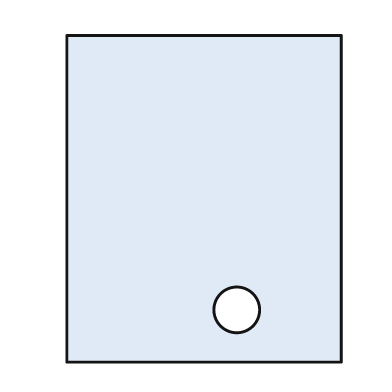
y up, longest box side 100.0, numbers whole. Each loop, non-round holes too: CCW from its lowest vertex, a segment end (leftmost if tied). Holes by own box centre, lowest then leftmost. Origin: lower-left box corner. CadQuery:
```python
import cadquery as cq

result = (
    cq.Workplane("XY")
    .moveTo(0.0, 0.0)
    .lineTo(84.0, 0.0)
    .lineTo(84.0, 100.0)
    .lineTo(0.0, 100.0)
    .close()
    .moveTo(52.0, 16.0)
    .circle(7.0)
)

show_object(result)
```